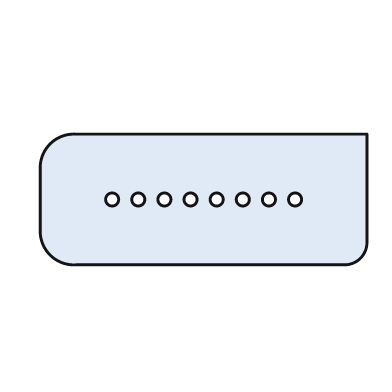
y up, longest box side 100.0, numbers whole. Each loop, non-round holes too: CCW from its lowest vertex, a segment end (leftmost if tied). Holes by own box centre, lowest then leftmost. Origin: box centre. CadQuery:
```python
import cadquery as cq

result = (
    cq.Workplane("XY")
    .moveTo(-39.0, -20.0)
    .lineTo(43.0, -20.0)
    .threePointArc((48.0, -18.0), (50.0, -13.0))
    .lineTo(50.0, 20.0)
    .lineTo(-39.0, 20.0)
    .threePointArc((-47.0, 17.0), (-50.0, 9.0))
    .lineTo(-50.0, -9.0)
    .threePointArc((-47.0, -17.0), (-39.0, -20.0))
    .close()
    .moveTo(-28.0, 0.0)
    .circle(2.0)
    .moveTo(-20.0, 0.0)
    .circle(2.0)
    .moveTo(-12.0, 0.0)
    .circle(2.0)
    .moveTo(-4.0, 0.0)
    .circle(2.0)
    .moveTo(4.0, 0.0)
    .circle(2.0)
    .moveTo(12.0, 0.0)
    .circle(2.0)
    .moveTo(20.0, 0.0)
    .circle(2.0)
    .moveTo(28.0, 0.0)
    .circle(2.0)
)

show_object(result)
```